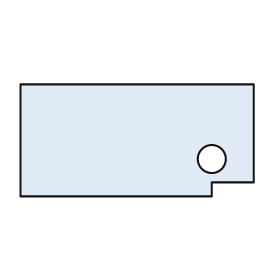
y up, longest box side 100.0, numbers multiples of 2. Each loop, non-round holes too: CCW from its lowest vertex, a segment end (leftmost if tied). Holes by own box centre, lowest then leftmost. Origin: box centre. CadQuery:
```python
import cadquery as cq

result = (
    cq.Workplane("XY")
    .moveTo(-50.0, -24.0)
    .lineTo(32.0, -24.0)
    .lineTo(32.0, -18.0)
    .lineTo(50.0, -18.0)
    .lineTo(50.0, 24.0)
    .lineTo(-50.0, 24.0)
    .close()
    .moveTo(32.0, -8.0)
    .circle(6.0)
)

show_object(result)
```